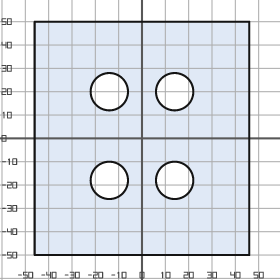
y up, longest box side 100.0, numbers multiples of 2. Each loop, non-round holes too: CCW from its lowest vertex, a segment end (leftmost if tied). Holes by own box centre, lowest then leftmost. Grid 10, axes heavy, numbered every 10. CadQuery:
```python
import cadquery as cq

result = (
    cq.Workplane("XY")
    .moveTo(-46.0, -50.0)
    .lineTo(46.0, -50.0)
    .lineTo(46.0, 50.0)
    .lineTo(-46.0, 50.0)
    .close()
    .moveTo(-14.0, -18.0)
    .circle(8.0)
    .moveTo(14.0, -18.0)
    .circle(8.0)
    .moveTo(-14.0, 20.0)
    .circle(8.0)
    .moveTo(14.0, 20.0)
    .circle(8.0)
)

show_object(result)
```